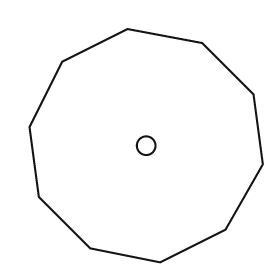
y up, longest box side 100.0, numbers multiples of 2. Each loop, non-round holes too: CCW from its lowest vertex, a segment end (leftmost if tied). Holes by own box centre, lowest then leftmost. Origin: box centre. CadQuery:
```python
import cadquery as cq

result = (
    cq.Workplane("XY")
    .moveTo(6.0, -50.0)
    .lineTo(34.0, -36.0)
    .lineTo(50.0, -8.0)
    .lineTo(46.0, 22.0)
    .lineTo(24.0, 44.0)
    .lineTo(-8.0, 50.0)
    .lineTo(-36.0, 36.0)
    .lineTo(-50.0, 8.0)
    .lineTo(-46.0, -22.0)
    .lineTo(-24.0, -44.0)
    .close()
    .moveTo(0.0, 0.0)
    .circle(4.0)
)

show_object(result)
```